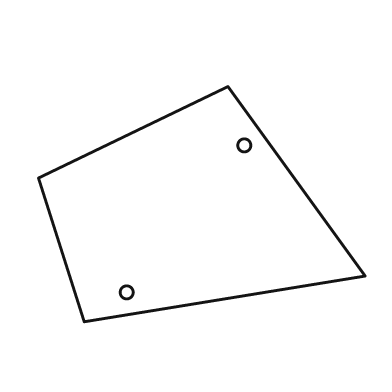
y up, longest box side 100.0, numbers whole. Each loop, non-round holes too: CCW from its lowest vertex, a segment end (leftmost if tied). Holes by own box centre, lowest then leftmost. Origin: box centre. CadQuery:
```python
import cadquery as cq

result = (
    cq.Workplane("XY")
    .moveTo(-36.0, -36.0)
    .lineTo(50.0, -22.0)
    .lineTo(8.0, 36.0)
    .lineTo(-50.0, 8.0)
    .close()
    .moveTo(-23.0, -27.0)
    .circle(2.0)
    .moveTo(13.0, 18.0)
    .circle(2.0)
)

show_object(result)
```